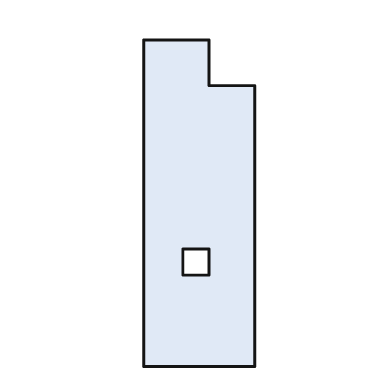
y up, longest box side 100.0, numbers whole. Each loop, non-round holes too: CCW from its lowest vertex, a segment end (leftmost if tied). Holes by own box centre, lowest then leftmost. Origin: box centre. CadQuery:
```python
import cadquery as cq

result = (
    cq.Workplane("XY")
    .moveTo(-17.0, -50.0)
    .lineTo(17.0, -50.0)
    .lineTo(17.0, 36.0)
    .lineTo(3.0, 36.0)
    .lineTo(3.0, 50.0)
    .lineTo(-17.0, 50.0)
    .close()
    .moveTo(-5.0, -22.0)
    .lineTo(3.0, -22.0)
    .lineTo(3.0, -14.0)
    .lineTo(-5.0, -14.0)
    .close()
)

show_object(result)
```